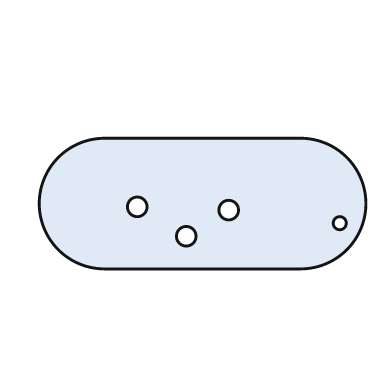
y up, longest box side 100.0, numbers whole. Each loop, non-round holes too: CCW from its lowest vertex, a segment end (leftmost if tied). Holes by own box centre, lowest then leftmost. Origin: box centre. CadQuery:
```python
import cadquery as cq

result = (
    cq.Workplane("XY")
    .moveTo(-30.0, -20.0)
    .lineTo(30.0, -20.0)
    .threePointArc((50.0, 0.0), (30.0, 20.0))
    .lineTo(-30.0, 20.0)
    .threePointArc((-50.0, 0.0), (-30.0, -20.0))
    .close()
    .moveTo(-5.0, -10.0)
    .circle(3.0)
    .moveTo(42.0, -6.0)
    .circle(2.0)
    .moveTo(8.0, -2.0)
    .circle(3.0)
    .moveTo(-20.0, -1.0)
    .circle(3.0)
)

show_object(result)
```